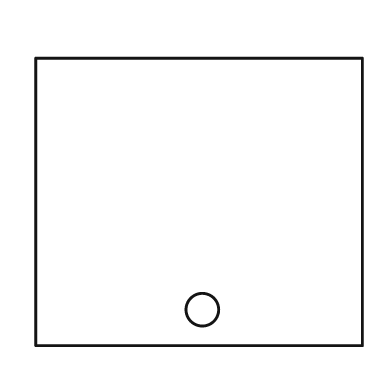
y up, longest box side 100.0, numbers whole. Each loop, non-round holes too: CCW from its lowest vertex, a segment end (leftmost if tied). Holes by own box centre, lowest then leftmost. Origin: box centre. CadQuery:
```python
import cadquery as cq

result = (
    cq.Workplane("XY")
    .moveTo(-50.0, -44.0)
    .lineTo(50.0, -44.0)
    .lineTo(50.0, 44.0)
    .lineTo(-50.0, 44.0)
    .close()
    .moveTo(1.0, -33.0)
    .circle(5.0)
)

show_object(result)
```